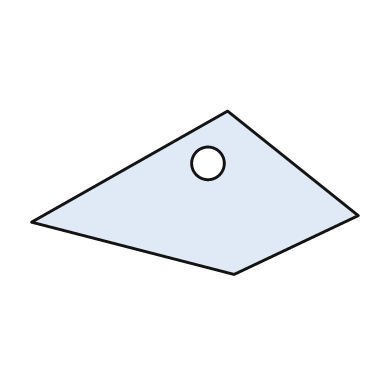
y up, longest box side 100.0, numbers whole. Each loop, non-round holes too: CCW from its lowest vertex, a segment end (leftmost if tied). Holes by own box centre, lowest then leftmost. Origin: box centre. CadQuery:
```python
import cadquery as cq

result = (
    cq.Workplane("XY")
    .moveTo(12.0, -25.0)
    .lineTo(50.0, -7.0)
    .lineTo(10.0, 25.0)
    .lineTo(-50.0, -9.0)
    .close()
    .moveTo(4.0, 9.0)
    .circle(5.0)
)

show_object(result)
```